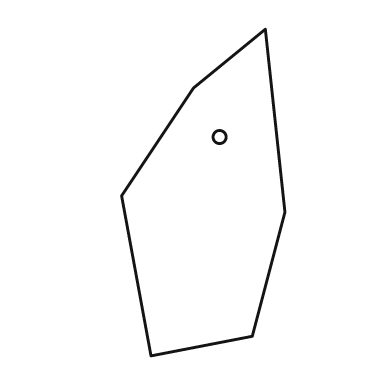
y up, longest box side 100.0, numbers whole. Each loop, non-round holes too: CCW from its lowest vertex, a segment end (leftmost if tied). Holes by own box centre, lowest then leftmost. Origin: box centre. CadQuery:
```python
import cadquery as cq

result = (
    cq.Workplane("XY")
    .moveTo(-16.0, -50.0)
    .lineTo(15.0, -44.0)
    .lineTo(25.0, -6.0)
    .lineTo(19.0, 50.0)
    .lineTo(-3.0, 32.0)
    .lineTo(-25.0, -1.0)
    .close()
    .moveTo(5.0, 17.0)
    .circle(2.0)
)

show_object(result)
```